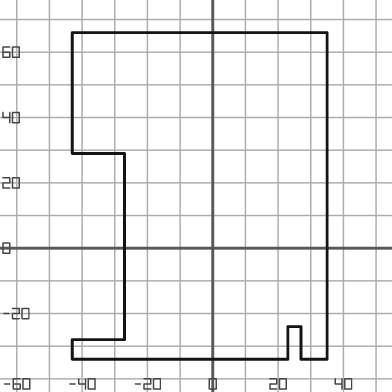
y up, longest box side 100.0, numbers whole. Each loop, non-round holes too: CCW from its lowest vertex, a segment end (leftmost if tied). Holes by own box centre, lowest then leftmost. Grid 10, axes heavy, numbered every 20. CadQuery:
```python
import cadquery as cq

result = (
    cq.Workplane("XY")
    .moveTo(-43.0, -34.0)
    .lineTo(23.0, -34.0)
    .lineTo(23.0, -24.0)
    .lineTo(27.0, -24.0)
    .lineTo(27.0, -34.0)
    .lineTo(35.0, -34.0)
    .lineTo(35.0, 66.0)
    .lineTo(-43.0, 66.0)
    .lineTo(-43.0, 29.0)
    .lineTo(-27.0, 29.0)
    .lineTo(-27.0, -28.0)
    .lineTo(-43.0, -28.0)
    .close()
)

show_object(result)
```